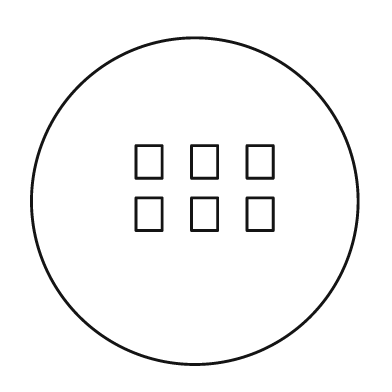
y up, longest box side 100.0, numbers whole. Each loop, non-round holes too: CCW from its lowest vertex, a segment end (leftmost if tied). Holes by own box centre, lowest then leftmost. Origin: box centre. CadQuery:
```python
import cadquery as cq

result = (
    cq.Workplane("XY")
    .moveTo(0.0, 0.0)
    .circle(50.0)
    .moveTo(-18.0, -9.0)
    .lineTo(-10.0, -9.0)
    .lineTo(-10.0, 1.0)
    .lineTo(-18.0, 1.0)
    .close()
    .moveTo(-1.0, -9.0)
    .lineTo(7.0, -9.0)
    .lineTo(7.0, 1.0)
    .lineTo(-1.0, 1.0)
    .close()
    .moveTo(16.0, -9.0)
    .lineTo(24.0, -9.0)
    .lineTo(24.0, 1.0)
    .lineTo(16.0, 1.0)
    .close()
    .moveTo(-18.0, 7.0)
    .lineTo(-10.0, 7.0)
    .lineTo(-10.0, 17.0)
    .lineTo(-18.0, 17.0)
    .close()
    .moveTo(-1.0, 7.0)
    .lineTo(7.0, 7.0)
    .lineTo(7.0, 17.0)
    .lineTo(-1.0, 17.0)
    .close()
    .moveTo(16.0, 7.0)
    .lineTo(24.0, 7.0)
    .lineTo(24.0, 17.0)
    .lineTo(16.0, 17.0)
    .close()
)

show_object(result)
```